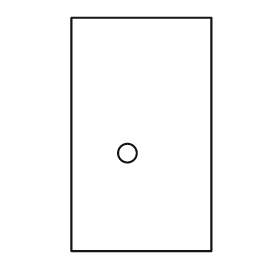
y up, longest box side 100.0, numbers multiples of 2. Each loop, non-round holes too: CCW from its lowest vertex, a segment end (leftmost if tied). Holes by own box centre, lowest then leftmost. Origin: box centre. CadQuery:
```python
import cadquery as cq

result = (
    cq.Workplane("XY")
    .moveTo(-30.0, -50.0)
    .lineTo(30.0, -50.0)
    .lineTo(30.0, 50.0)
    .lineTo(-30.0, 50.0)
    .close()
    .moveTo(-6.0, -8.0)
    .circle(4.0)
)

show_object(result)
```